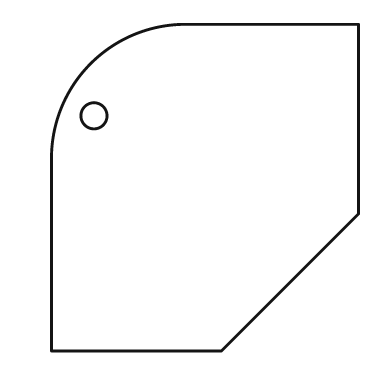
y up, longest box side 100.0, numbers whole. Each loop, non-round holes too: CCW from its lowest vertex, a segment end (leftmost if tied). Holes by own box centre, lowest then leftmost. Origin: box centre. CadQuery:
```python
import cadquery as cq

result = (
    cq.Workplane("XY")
    .moveTo(-47.0, -50.0)
    .lineTo(5.0, -50.0)
    .lineTo(47.0, -8.0)
    .lineTo(47.0, 50.0)
    .lineTo(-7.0, 50.0)
    .threePointArc((-35.0, 38.0), (-47.0, 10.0))
    .close()
    .moveTo(-34.0, 22.0)
    .circle(4.0)
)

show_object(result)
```